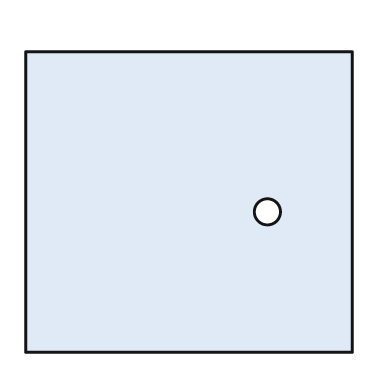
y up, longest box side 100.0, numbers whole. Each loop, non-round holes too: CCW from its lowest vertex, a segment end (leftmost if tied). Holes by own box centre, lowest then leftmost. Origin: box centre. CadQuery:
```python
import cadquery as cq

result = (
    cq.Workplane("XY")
    .moveTo(-50.0, -46.0)
    .lineTo(50.0, -46.0)
    .lineTo(50.0, 46.0)
    .lineTo(-50.0, 46.0)
    .close()
    .moveTo(24.0, -3.0)
    .circle(4.0)
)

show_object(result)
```